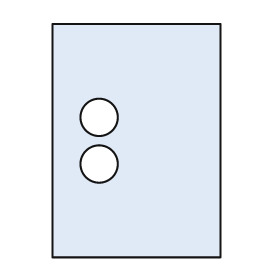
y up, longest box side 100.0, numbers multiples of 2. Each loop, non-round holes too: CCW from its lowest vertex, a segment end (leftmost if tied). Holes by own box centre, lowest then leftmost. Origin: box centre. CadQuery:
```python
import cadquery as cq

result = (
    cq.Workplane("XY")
    .moveTo(-36.0, -50.0)
    .lineTo(36.0, -50.0)
    .lineTo(36.0, 50.0)
    .lineTo(-36.0, 50.0)
    .close()
    .moveTo(-16.0, -10.0)
    .circle(8.0)
    .moveTo(-16.0, 10.0)
    .circle(8.0)
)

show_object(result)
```